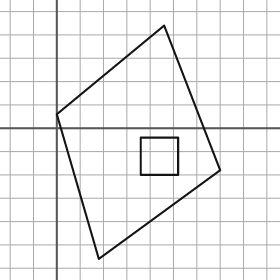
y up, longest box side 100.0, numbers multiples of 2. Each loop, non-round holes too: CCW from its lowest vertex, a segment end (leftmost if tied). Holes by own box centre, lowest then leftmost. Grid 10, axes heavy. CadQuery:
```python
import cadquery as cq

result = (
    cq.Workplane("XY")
    .moveTo(18.0, -56.0)
    .lineTo(70.0, -18.0)
    .lineTo(46.0, 44.0)
    .lineTo(0.0, 6.0)
    .close()
    .moveTo(36.0, -20.0)
    .lineTo(52.0, -20.0)
    .lineTo(52.0, -4.0)
    .lineTo(36.0, -4.0)
    .close()
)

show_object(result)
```